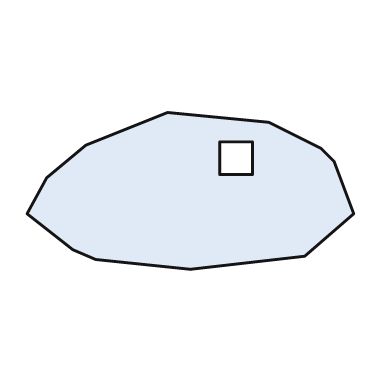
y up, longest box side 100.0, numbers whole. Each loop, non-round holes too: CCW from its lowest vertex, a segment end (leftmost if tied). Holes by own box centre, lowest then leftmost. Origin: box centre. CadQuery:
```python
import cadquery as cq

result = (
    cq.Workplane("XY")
    .moveTo(0.0, -24.0)
    .lineTo(35.0, -20.0)
    .lineTo(50.0, -7.0)
    .lineTo(44.0, 9.0)
    .lineTo(40.0, 13.0)
    .lineTo(24.0, 21.0)
    .lineTo(-7.0, 24.0)
    .lineTo(-32.0, 14.0)
    .lineTo(-44.0, 4.0)
    .lineTo(-50.0, -7.0)
    .lineTo(-36.0, -18.0)
    .lineTo(-29.0, -21.0)
    .close()
    .moveTo(9.0, 5.0)
    .lineTo(19.0, 5.0)
    .lineTo(19.0, 15.0)
    .lineTo(9.0, 15.0)
    .close()
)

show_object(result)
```